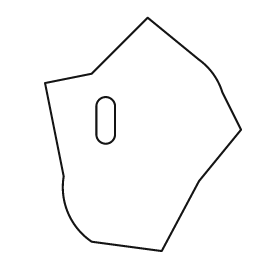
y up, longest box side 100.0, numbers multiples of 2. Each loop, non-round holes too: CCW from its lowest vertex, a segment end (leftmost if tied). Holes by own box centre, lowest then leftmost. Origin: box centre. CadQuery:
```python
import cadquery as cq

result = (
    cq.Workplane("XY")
    .moveTo(8.0, -50.0)
    .lineTo(24.0, -20.0)
    .lineTo(42.0, 2.0)
    .lineTo(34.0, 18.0)
    .threePointArc((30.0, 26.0), (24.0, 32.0))
    .lineTo(2.0, 50.0)
    .lineTo(-22.0, 26.0)
    .lineTo(-42.0, 22.0)
    .lineTo(-34.0, -18.0)
    .threePointArc((-32.0, -34.0), (-22.0, -46.0))
    .close()
    .moveTo(-20.0, 0.0)
    .threePointArc((-16.0, -4.0), (-12.0, 0.0))
    .lineTo(-12.0, 12.0)
    .threePointArc((-16.0, 16.0), (-20.0, 12.0))
    .close()
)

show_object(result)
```